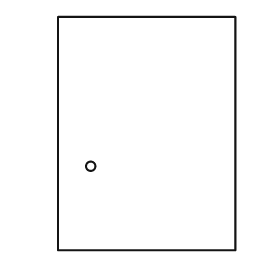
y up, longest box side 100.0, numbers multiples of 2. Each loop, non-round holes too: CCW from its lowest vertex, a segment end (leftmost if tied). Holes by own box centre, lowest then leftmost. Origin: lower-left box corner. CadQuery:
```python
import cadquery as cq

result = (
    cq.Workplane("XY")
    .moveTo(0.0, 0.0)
    .lineTo(76.0, 0.0)
    .lineTo(76.0, 100.0)
    .lineTo(0.0, 100.0)
    .close()
    .moveTo(14.0, 36.0)
    .circle(2.0)
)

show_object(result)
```